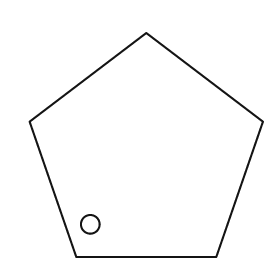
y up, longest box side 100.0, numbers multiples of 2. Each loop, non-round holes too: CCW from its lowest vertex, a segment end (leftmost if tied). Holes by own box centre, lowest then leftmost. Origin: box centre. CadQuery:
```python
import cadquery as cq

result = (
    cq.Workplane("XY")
    .moveTo(-30.0, -48.0)
    .lineTo(30.0, -48.0)
    .lineTo(50.0, 10.0)
    .lineTo(0.0, 48.0)
    .lineTo(-50.0, 10.0)
    .close()
    .moveTo(-24.0, -34.0)
    .circle(4.0)
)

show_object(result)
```